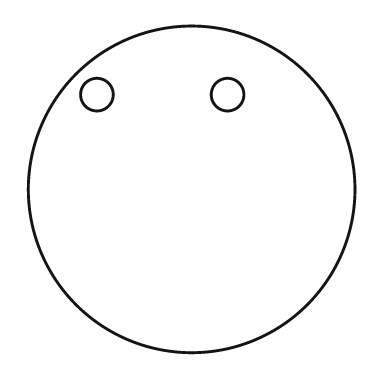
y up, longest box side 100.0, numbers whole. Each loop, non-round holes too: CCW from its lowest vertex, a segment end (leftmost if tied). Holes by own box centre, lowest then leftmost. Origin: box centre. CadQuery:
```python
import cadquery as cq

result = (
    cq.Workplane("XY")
    .moveTo(0.0, 0.0)
    .circle(50.0)
    .moveTo(-29.0, 29.0)
    .circle(5.0)
    .moveTo(11.0, 29.0)
    .circle(5.0)
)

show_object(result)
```